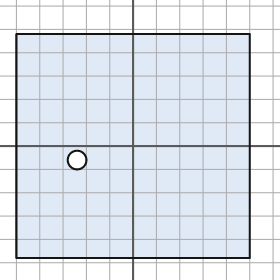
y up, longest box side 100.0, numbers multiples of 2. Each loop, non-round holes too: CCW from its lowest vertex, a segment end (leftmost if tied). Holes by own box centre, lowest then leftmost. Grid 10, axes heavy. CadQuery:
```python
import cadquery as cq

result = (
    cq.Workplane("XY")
    .moveTo(-50.0, -48.0)
    .lineTo(50.0, -48.0)
    .lineTo(50.0, 48.0)
    .lineTo(-50.0, 48.0)
    .close()
    .moveTo(-24.0, -6.0)
    .circle(4.0)
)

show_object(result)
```